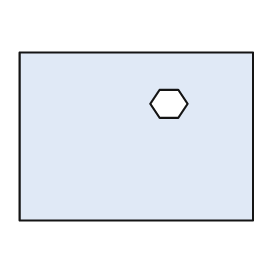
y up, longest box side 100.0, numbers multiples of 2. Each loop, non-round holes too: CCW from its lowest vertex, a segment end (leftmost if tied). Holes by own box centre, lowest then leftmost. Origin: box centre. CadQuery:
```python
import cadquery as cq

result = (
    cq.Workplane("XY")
    .moveTo(-50.0, -36.0)
    .lineTo(50.0, -36.0)
    .lineTo(50.0, 36.0)
    .lineTo(-50.0, 36.0)
    .close()
    .moveTo(10.0, 8.0)
    .lineTo(18.0, 8.0)
    .lineTo(22.0, 14.0)
    .lineTo(18.0, 20.0)
    .lineTo(10.0, 20.0)
    .lineTo(6.0, 14.0)
    .close()
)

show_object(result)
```